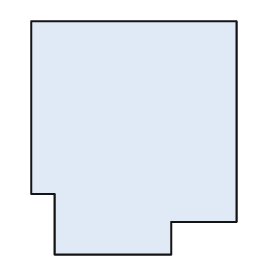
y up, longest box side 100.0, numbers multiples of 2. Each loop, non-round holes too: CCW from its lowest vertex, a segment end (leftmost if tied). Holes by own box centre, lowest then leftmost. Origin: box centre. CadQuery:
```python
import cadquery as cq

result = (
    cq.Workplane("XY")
    .moveTo(-34.0, -50.0)
    .lineTo(16.0, -50.0)
    .lineTo(16.0, -36.0)
    .lineTo(44.0, -36.0)
    .lineTo(44.0, 50.0)
    .lineTo(-44.0, 50.0)
    .lineTo(-44.0, -24.0)
    .lineTo(-34.0, -24.0)
    .close()
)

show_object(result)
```